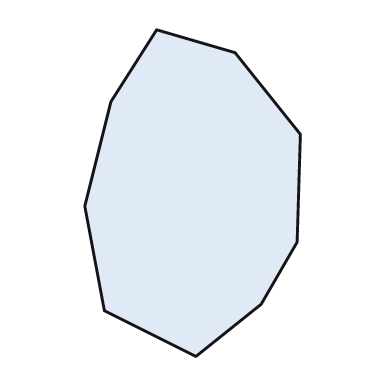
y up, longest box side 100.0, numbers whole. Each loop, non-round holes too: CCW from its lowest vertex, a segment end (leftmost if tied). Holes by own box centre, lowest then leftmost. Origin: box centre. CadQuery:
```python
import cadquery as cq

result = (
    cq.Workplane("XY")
    .moveTo(1.0, -50.0)
    .lineTo(21.0, -34.0)
    .lineTo(32.0, -15.0)
    .lineTo(33.0, 18.0)
    .lineTo(13.0, 43.0)
    .lineTo(-11.0, 50.0)
    .lineTo(-25.0, 28.0)
    .lineTo(-33.0, -4.0)
    .lineTo(-27.0, -36.0)
    .close()
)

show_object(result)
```